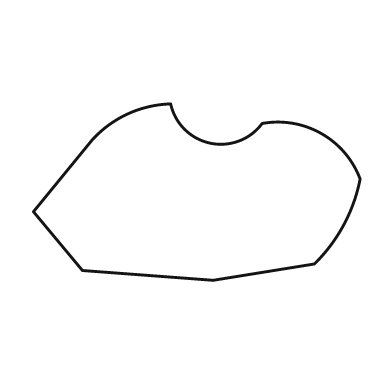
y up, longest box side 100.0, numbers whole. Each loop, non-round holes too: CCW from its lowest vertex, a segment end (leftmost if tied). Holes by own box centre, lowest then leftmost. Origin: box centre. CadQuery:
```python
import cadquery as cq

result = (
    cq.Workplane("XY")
    .moveTo(5.0, -27.0)
    .lineTo(36.0, -22.0)
    .threePointArc((45.0, -10.0), (50.0, 4.0))
    .threePointArc((38.0, 18.0), (20.0, 21.0))
    .threePointArc((4.0, 15.0), (-8.0, 27.0))
    .threePointArc((-21.0, 24.0), (-32.0, 16.0))
    .lineTo(-50.0, -6.0)
    .lineTo(-35.0, -24.0)
    .close()
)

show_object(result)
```